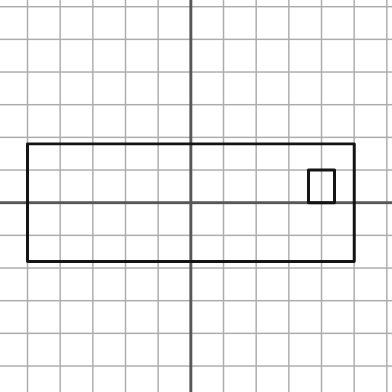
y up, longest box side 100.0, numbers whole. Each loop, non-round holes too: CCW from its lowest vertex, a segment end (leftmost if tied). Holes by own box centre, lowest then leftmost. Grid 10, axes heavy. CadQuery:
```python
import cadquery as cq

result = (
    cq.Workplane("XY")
    .moveTo(-50.0, -18.0)
    .lineTo(50.0, -18.0)
    .lineTo(50.0, 18.0)
    .lineTo(-50.0, 18.0)
    .close()
    .moveTo(36.0, 0.0)
    .lineTo(44.0, 0.0)
    .lineTo(44.0, 10.0)
    .lineTo(36.0, 10.0)
    .close()
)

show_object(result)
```